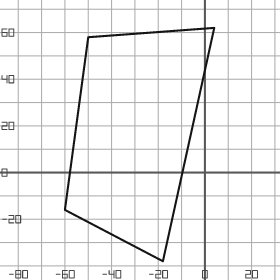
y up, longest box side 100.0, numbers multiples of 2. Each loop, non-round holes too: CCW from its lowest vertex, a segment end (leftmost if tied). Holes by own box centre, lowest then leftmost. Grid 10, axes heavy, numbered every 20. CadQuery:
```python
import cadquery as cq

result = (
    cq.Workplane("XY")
    .moveTo(-18.0, -38.0)
    .lineTo(4.0, 62.0)
    .lineTo(-50.0, 58.0)
    .lineTo(-60.0, -16.0)
    .close()
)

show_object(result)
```